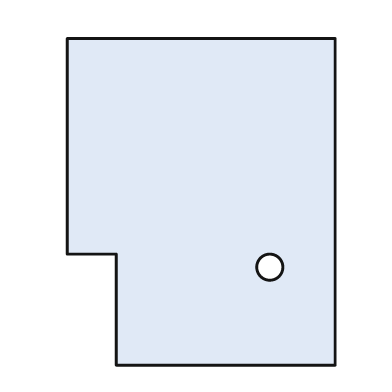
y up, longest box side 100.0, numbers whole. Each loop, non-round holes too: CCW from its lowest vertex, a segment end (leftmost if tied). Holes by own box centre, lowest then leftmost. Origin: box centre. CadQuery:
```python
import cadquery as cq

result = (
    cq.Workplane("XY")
    .moveTo(-26.0, -50.0)
    .lineTo(41.0, -50.0)
    .lineTo(41.0, 50.0)
    .lineTo(-41.0, 50.0)
    .lineTo(-41.0, -16.0)
    .lineTo(-26.0, -16.0)
    .close()
    .moveTo(21.0, -20.0)
    .circle(4.0)
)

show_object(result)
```